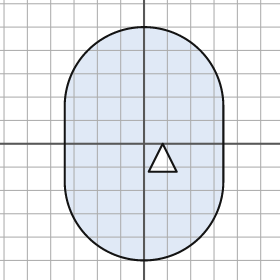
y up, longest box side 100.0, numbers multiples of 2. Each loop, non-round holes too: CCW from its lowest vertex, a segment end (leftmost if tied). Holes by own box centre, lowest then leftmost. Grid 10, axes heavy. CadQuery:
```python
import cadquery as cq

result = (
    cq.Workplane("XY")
    .moveTo(-34.0, -16.0)
    .threePointArc((0.0, -50.0), (34.0, -16.0))
    .lineTo(34.0, 16.0)
    .threePointArc((0.0, 50.0), (-34.0, 16.0))
    .close()
    .moveTo(2.0, -12.0)
    .lineTo(14.0, -12.0)
    .lineTo(8.0, 0.0)
    .close()
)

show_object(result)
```